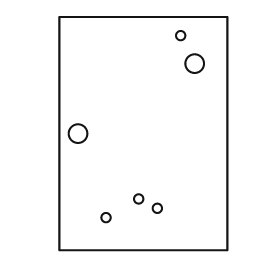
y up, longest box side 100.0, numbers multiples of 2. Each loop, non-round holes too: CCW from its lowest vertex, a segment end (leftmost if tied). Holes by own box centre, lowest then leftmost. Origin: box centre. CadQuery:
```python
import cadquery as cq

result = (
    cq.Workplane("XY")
    .moveTo(-36.0, -50.0)
    .lineTo(36.0, -50.0)
    .lineTo(36.0, 50.0)
    .lineTo(-36.0, 50.0)
    .close()
    .moveTo(-16.0, -36.0)
    .circle(2.0)
    .moveTo(6.0, -32.0)
    .circle(2.0)
    .moveTo(-2.0, -28.0)
    .circle(2.0)
    .moveTo(-28.0, 0.0)
    .circle(4.0)
    .moveTo(22.0, 30.0)
    .circle(4.0)
    .moveTo(16.0, 42.0)
    .circle(2.0)
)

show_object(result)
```